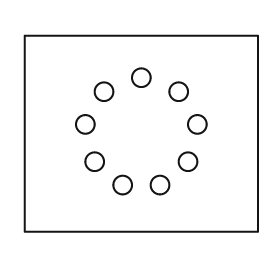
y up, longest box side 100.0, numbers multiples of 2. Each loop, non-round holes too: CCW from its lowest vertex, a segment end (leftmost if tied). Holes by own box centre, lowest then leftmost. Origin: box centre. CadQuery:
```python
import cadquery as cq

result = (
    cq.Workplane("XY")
    .moveTo(-50.0, -42.0)
    .lineTo(50.0, -42.0)
    .lineTo(50.0, 42.0)
    .lineTo(-50.0, 42.0)
    .close()
    .moveTo(-8.0, -22.0)
    .circle(4.0)
    .moveTo(8.0, -22.0)
    .circle(4.0)
    .moveTo(-20.0, -12.0)
    .circle(4.0)
    .moveTo(20.0, -12.0)
    .circle(4.0)
    .moveTo(-24.0, 4.0)
    .circle(4.0)
    .moveTo(24.0, 4.0)
    .circle(4.0)
    .moveTo(-16.0, 18.0)
    .circle(4.0)
    .moveTo(16.0, 18.0)
    .circle(4.0)
    .moveTo(0.0, 24.0)
    .circle(4.0)
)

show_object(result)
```